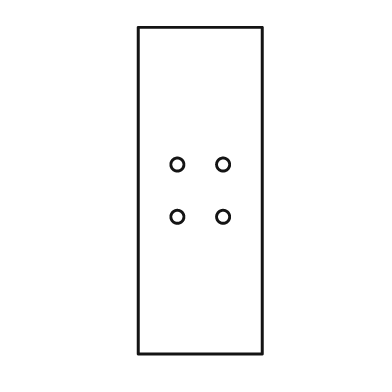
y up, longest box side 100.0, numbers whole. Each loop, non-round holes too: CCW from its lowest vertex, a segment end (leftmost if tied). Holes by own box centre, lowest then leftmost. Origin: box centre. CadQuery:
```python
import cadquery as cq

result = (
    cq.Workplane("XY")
    .moveTo(-19.0, -50.0)
    .lineTo(19.0, -50.0)
    .lineTo(19.0, 50.0)
    .lineTo(-19.0, 50.0)
    .close()
    .moveTo(-7.0, -8.0)
    .circle(2.0)
    .moveTo(7.0, -8.0)
    .circle(2.0)
    .moveTo(-7.0, 8.0)
    .circle(2.0)
    .moveTo(7.0, 8.0)
    .circle(2.0)
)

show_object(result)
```